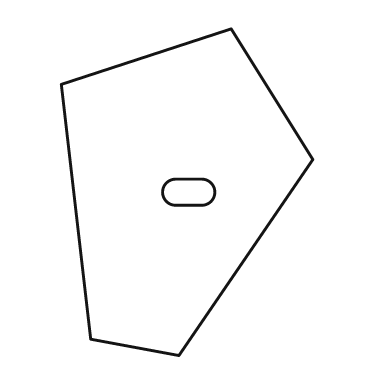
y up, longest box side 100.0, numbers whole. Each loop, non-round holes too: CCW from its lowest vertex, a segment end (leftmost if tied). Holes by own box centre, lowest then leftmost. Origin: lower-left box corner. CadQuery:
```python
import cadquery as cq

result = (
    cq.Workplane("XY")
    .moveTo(36.0, 0.0)
    .lineTo(77.0, 60.0)
    .lineTo(52.0, 100.0)
    .lineTo(0.0, 83.0)
    .lineTo(9.0, 5.0)
    .close()
    .moveTo(35.0, 46.0)
    .lineTo(43.0, 46.0)
    .threePointArc((47.0, 50.0), (43.0, 54.0))
    .lineTo(35.0, 54.0)
    .threePointArc((31.0, 50.0), (35.0, 46.0))
    .close()
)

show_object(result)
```